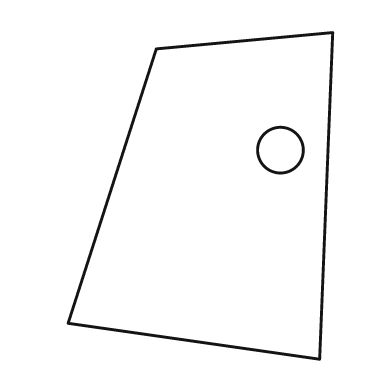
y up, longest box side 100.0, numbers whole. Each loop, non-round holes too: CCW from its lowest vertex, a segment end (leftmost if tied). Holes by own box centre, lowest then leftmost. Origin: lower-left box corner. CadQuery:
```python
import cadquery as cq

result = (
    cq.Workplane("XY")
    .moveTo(77.0, 0.0)
    .lineTo(81.0, 100.0)
    .lineTo(27.0, 95.0)
    .lineTo(0.0, 11.0)
    .close()
    .moveTo(65.0, 64.0)
    .circle(7.0)
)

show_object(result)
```